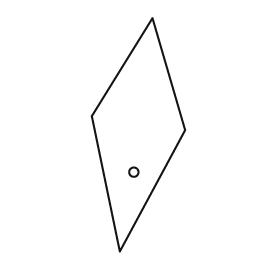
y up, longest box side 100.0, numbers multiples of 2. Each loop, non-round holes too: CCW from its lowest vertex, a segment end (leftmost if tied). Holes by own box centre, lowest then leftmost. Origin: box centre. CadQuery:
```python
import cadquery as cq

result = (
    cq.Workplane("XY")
    .moveTo(-8.0, -50.0)
    .lineTo(20.0, 2.0)
    .lineTo(6.0, 50.0)
    .lineTo(-20.0, 8.0)
    .close()
    .moveTo(-2.0, -16.0)
    .circle(2.0)
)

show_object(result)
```